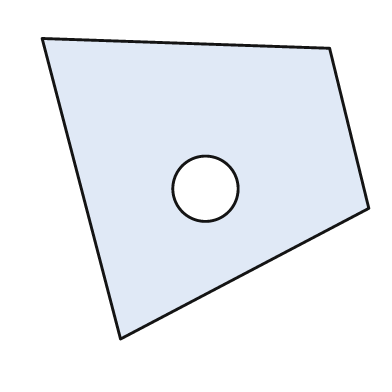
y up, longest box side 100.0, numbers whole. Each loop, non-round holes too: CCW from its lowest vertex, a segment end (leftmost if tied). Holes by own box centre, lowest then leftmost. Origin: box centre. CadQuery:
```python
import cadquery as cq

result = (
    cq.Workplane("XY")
    .moveTo(-26.0, -46.0)
    .lineTo(50.0, -6.0)
    .lineTo(38.0, 43.0)
    .lineTo(-50.0, 46.0)
    .close()
    .moveTo(0.0, 0.0)
    .circle(10.0)
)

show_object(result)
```